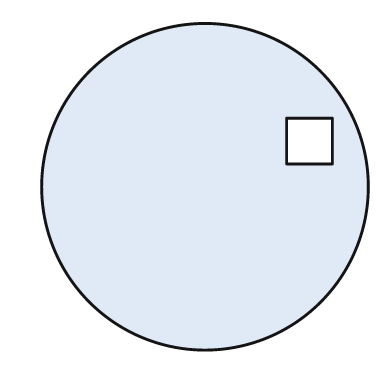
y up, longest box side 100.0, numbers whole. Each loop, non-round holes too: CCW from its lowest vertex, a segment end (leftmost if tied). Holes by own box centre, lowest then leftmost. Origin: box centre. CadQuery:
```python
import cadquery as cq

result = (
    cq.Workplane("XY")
    .moveTo(0.0, 0.0)
    .circle(50.0)
    .moveTo(25.0, 7.0)
    .lineTo(39.0, 7.0)
    .lineTo(39.0, 21.0)
    .lineTo(25.0, 21.0)
    .close()
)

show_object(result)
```